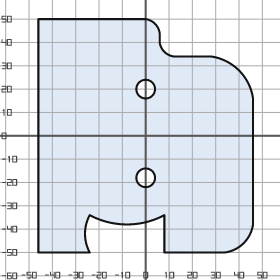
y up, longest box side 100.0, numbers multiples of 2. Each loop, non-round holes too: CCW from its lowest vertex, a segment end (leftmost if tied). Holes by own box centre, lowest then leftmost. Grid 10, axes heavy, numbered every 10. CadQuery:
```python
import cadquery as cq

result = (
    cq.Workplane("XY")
    .moveTo(-46.0, -50.0)
    .lineTo(-24.0, -50.0)
    .threePointArc((-26.0, -42.0), (-24.0, -34.0))
    .threePointArc((-8.0, -38.0), (8.0, -34.0))
    .lineTo(8.0, -50.0)
    .lineTo(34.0, -50.0)
    .threePointArc((42.0, -46.0), (46.0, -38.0))
    .lineTo(46.0, 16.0)
    .threePointArc((40.0, 28.0), (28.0, 34.0))
    .lineTo(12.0, 34.0)
    .threePointArc((8.0, 36.0), (6.0, 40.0))
    .lineTo(6.0, 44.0)
    .threePointArc((4.0, 48.0), (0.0, 50.0))
    .lineTo(-46.0, 50.0)
    .close()
    .moveTo(0.0, -18.0)
    .circle(4.0)
    .moveTo(0.0, 20.0)
    .circle(4.0)
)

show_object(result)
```